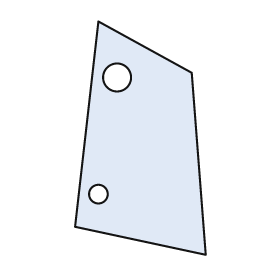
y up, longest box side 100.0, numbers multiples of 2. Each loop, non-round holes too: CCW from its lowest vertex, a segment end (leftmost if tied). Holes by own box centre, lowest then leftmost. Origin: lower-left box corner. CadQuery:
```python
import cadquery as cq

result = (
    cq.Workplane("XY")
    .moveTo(56.0, 0.0)
    .lineTo(50.0, 78.0)
    .lineTo(10.0, 100.0)
    .lineTo(0.0, 12.0)
    .close()
    .moveTo(10.0, 26.0)
    .circle(4.0)
    .moveTo(18.0, 76.0)
    .circle(6.0)
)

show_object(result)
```